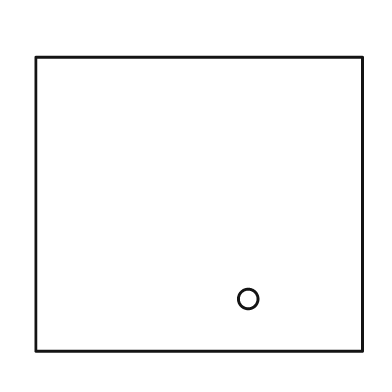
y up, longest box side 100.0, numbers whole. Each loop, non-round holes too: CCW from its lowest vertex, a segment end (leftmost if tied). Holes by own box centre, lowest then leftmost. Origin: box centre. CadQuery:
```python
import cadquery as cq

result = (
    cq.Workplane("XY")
    .moveTo(-50.0, -45.0)
    .lineTo(50.0, -45.0)
    .lineTo(50.0, 45.0)
    .lineTo(-50.0, 45.0)
    .close()
    .moveTo(15.0, -29.0)
    .circle(3.0)
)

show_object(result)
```